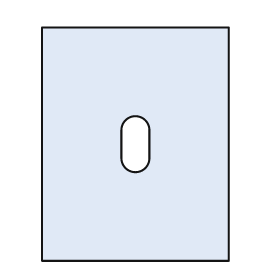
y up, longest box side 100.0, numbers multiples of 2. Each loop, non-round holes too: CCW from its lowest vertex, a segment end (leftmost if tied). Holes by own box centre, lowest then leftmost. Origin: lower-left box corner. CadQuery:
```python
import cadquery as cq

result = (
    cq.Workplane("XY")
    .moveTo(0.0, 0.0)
    .lineTo(80.0, 0.0)
    .lineTo(80.0, 100.0)
    .lineTo(0.0, 100.0)
    .close()
    .moveTo(34.0, 44.0)
    .threePointArc((40.0, 38.0), (46.0, 44.0))
    .lineTo(46.0, 56.0)
    .threePointArc((40.0, 62.0), (34.0, 56.0))
    .close()
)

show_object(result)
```